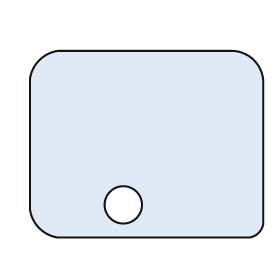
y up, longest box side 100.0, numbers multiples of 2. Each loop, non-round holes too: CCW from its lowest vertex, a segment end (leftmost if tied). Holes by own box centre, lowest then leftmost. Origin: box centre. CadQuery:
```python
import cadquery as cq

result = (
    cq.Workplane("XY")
    .moveTo(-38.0, -40.0)
    .lineTo(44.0, -40.0)
    .threePointArc((48.0, -38.0), (50.0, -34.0))
    .lineTo(50.0, 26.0)
    .threePointArc((46.0, 36.0), (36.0, 40.0))
    .lineTo(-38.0, 40.0)
    .threePointArc((-46.0, 36.0), (-50.0, 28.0))
    .lineTo(-50.0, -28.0)
    .threePointArc((-46.0, -36.0), (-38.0, -40.0))
    .close()
    .moveTo(-10.0, -26.0)
    .circle(8.0)
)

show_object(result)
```